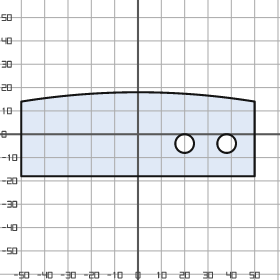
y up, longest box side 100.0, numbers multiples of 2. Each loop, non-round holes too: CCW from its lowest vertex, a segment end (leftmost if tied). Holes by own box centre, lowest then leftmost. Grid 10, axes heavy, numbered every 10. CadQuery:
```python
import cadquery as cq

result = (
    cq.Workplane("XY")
    .moveTo(-50.0, -18.0)
    .lineTo(50.0, -18.0)
    .lineTo(50.0, 14.0)
    .threePointArc((0.0, 18.0), (-50.0, 14.0))
    .close()
    .moveTo(20.0, -4.0)
    .circle(4.0)
    .moveTo(38.0, -4.0)
    .circle(4.0)
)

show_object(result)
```